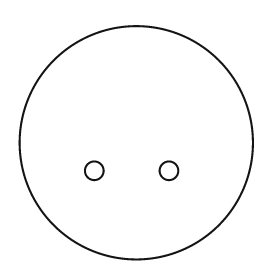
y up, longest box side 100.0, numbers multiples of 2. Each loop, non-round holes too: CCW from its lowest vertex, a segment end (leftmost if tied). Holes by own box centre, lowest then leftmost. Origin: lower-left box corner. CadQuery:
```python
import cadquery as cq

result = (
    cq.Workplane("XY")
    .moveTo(50.0, 50.0)
    .circle(50.0)
    .moveTo(32.0, 38.0)
    .circle(4.0)
    .moveTo(64.0, 38.0)
    .circle(4.0)
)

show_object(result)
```